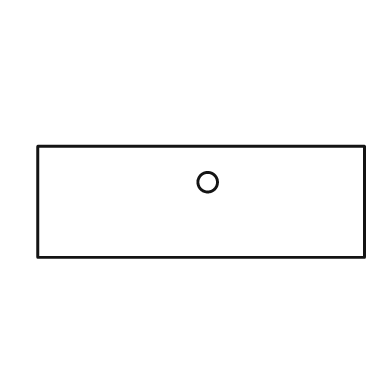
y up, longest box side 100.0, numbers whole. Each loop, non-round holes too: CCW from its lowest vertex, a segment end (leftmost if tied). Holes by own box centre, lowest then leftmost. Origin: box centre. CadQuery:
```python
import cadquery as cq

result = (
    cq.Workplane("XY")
    .moveTo(-50.0, -17.0)
    .lineTo(50.0, -17.0)
    .lineTo(50.0, 17.0)
    .lineTo(-50.0, 17.0)
    .close()
    .moveTo(2.0, 6.0)
    .circle(3.0)
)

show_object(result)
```